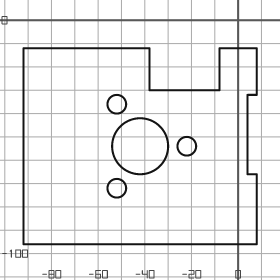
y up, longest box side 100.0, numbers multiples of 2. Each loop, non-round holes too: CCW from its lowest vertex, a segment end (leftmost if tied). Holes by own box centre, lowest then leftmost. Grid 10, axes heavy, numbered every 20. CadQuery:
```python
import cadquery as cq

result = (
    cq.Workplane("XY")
    .moveTo(-92.0, -96.0)
    .lineTo(8.0, -96.0)
    .lineTo(8.0, -66.0)
    .lineTo(4.0, -66.0)
    .lineTo(4.0, -32.0)
    .lineTo(8.0, -32.0)
    .lineTo(8.0, -12.0)
    .lineTo(-8.0, -12.0)
    .lineTo(-8.0, -30.0)
    .lineTo(-38.0, -30.0)
    .lineTo(-38.0, -12.0)
    .lineTo(-92.0, -12.0)
    .close()
    .moveTo(-52.0, -72.0)
    .circle(4.0)
    .moveTo(-42.0, -54.0)
    .circle(12.0)
    .moveTo(-22.0, -54.0)
    .circle(4.0)
    .moveTo(-52.0, -36.0)
    .circle(4.0)
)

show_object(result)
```